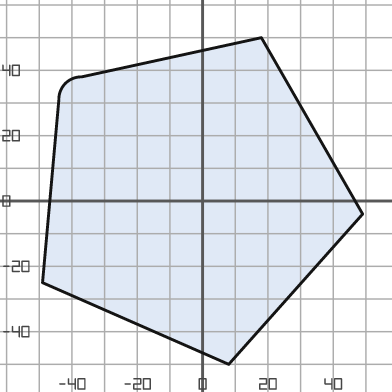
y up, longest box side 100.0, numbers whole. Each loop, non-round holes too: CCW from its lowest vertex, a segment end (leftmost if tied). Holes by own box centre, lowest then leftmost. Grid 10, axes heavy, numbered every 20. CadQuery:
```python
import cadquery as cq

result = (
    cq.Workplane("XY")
    .moveTo(8.0, -50.0)
    .lineTo(49.0, -4.0)
    .lineTo(18.0, 50.0)
    .lineTo(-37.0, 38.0)
    .threePointArc((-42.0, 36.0), (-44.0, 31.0))
    .lineTo(-49.0, -25.0)
    .close()
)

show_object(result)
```